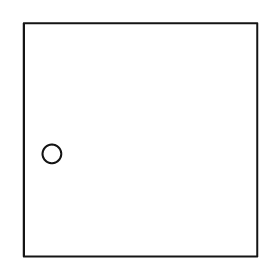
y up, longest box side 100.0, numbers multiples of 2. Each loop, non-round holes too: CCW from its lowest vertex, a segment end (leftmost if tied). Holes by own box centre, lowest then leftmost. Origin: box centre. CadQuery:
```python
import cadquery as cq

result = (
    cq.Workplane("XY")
    .moveTo(-50.0, -50.0)
    .lineTo(50.0, -50.0)
    .lineTo(50.0, 50.0)
    .lineTo(-50.0, 50.0)
    .close()
    .moveTo(-38.0, -6.0)
    .circle(4.0)
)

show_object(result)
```